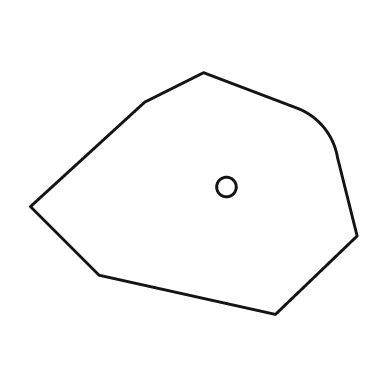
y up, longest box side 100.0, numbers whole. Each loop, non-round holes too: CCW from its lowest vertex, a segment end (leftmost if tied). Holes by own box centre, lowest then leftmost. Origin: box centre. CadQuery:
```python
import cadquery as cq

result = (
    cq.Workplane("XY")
    .moveTo(25.0, -37.0)
    .lineTo(50.0, -13.0)
    .lineTo(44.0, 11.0)
    .threePointArc((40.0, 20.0), (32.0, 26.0))
    .lineTo(3.0, 37.0)
    .lineTo(-15.0, 28.0)
    .lineTo(-50.0, -4.0)
    .lineTo(-29.0, -25.0)
    .close()
    .moveTo(10.0, 2.0)
    .circle(3.0)
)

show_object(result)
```